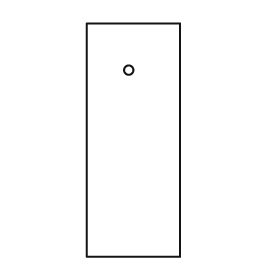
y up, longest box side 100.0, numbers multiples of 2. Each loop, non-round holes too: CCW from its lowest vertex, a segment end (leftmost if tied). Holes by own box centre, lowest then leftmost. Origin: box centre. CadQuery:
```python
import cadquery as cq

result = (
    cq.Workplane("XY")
    .moveTo(-20.0, -50.0)
    .lineTo(20.0, -50.0)
    .lineTo(20.0, 50.0)
    .lineTo(-20.0, 50.0)
    .close()
    .moveTo(-2.0, 30.0)
    .circle(2.0)
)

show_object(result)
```